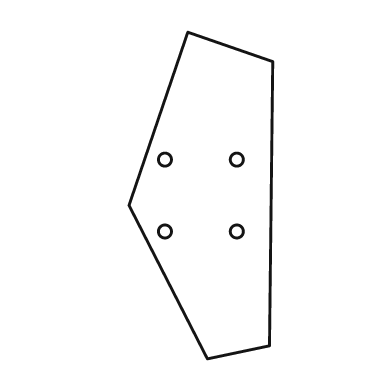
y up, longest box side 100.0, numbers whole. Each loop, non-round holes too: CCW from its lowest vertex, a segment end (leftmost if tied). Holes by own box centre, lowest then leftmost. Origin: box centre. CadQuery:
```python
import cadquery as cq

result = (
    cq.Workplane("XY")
    .moveTo(2.0, -50.0)
    .lineTo(21.0, -46.0)
    .lineTo(22.0, 41.0)
    .lineTo(-4.0, 50.0)
    .lineTo(-22.0, -3.0)
    .close()
    .moveTo(-11.0, -11.0)
    .circle(2.0)
    .moveTo(11.0, -11.0)
    .circle(2.0)
    .moveTo(-11.0, 11.0)
    .circle(2.0)
    .moveTo(11.0, 11.0)
    .circle(2.0)
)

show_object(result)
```